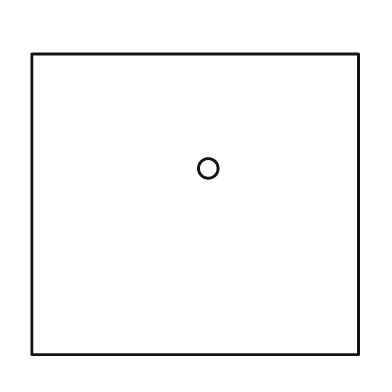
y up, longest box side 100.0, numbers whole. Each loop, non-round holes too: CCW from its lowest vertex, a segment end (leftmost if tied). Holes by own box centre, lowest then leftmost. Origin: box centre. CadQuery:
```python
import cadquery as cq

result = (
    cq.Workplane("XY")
    .moveTo(-50.0, -46.0)
    .lineTo(50.0, -46.0)
    .lineTo(50.0, 46.0)
    .lineTo(-50.0, 46.0)
    .close()
    .moveTo(4.0, 11.0)
    .circle(3.0)
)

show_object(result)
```